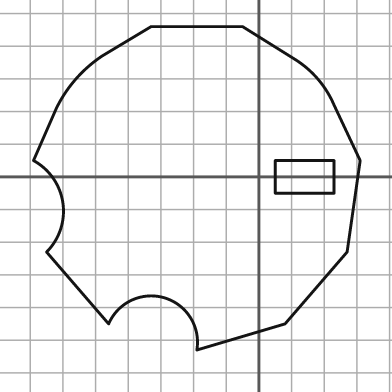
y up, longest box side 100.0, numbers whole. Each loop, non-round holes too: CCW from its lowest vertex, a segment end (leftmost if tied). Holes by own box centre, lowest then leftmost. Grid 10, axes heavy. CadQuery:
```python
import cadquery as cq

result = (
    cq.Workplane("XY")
    .moveTo(-19.0, -53.0)
    .lineTo(8.0, -45.0)
    .lineTo(27.0, -23.0)
    .lineTo(31.0, 5.0)
    .lineTo(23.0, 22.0)
    .threePointArc((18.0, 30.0), (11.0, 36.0))
    .lineTo(-5.0, 46.0)
    .lineTo(-33.0, 46.0)
    .lineTo(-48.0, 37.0)
    .threePointArc((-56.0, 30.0), (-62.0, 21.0))
    .lineTo(-69.0, 5.0)
    .threePointArc((-60.0, -8.0), (-65.0, -23.0))
    .lineTo(-46.0, -45.0)
    .threePointArc((-29.0, -37.0), (-19.0, -53.0))
    .close()
    .moveTo(5.0, -5.0)
    .lineTo(23.0, -5.0)
    .lineTo(23.0, 5.0)
    .lineTo(5.0, 5.0)
    .close()
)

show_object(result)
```